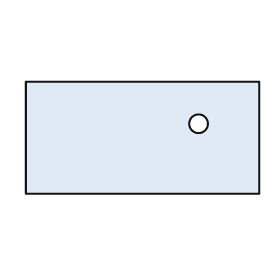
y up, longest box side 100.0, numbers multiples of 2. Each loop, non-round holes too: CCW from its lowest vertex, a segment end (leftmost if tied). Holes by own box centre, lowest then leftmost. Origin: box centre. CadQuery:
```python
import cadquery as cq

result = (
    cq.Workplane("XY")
    .moveTo(-50.0, -24.0)
    .lineTo(50.0, -24.0)
    .lineTo(50.0, 24.0)
    .lineTo(-50.0, 24.0)
    .close()
    .moveTo(24.0, 6.0)
    .circle(4.0)
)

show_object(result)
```